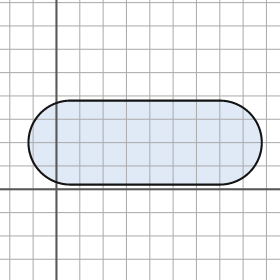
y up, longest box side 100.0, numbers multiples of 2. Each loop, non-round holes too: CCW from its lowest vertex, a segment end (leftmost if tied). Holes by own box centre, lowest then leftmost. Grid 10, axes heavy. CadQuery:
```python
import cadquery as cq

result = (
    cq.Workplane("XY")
    .moveTo(6.0, 2.0)
    .lineTo(70.0, 2.0)
    .threePointArc((88.0, 20.0), (70.0, 38.0))
    .lineTo(6.0, 38.0)
    .threePointArc((-12.0, 20.0), (6.0, 2.0))
    .close()
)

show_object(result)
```